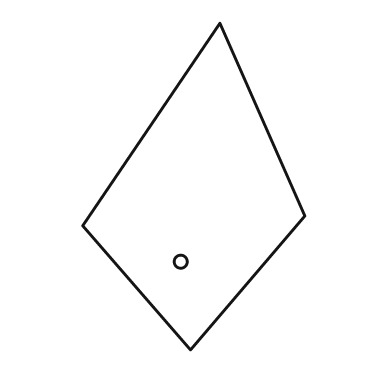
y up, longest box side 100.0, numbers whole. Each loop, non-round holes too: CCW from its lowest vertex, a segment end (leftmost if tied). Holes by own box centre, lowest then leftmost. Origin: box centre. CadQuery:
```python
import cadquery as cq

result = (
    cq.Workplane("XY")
    .moveTo(-1.0, -50.0)
    .lineTo(34.0, -9.0)
    .lineTo(8.0, 50.0)
    .lineTo(-34.0, -12.0)
    .close()
    .moveTo(-4.0, -23.0)
    .circle(2.0)
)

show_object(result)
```